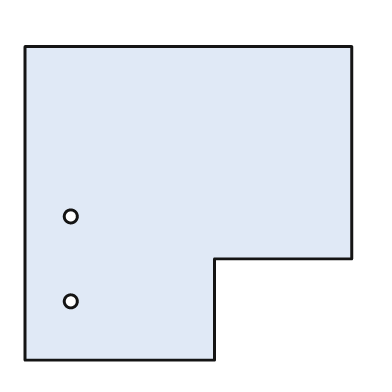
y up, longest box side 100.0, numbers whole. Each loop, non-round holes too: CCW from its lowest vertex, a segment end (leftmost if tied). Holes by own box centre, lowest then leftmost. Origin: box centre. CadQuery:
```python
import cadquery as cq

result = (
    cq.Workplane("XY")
    .moveTo(-50.0, -48.0)
    .lineTo(8.0, -48.0)
    .lineTo(8.0, -17.0)
    .lineTo(50.0, -17.0)
    .lineTo(50.0, 48.0)
    .lineTo(-50.0, 48.0)
    .close()
    .moveTo(-36.0, -30.0)
    .circle(2.0)
    .moveTo(-36.0, -4.0)
    .circle(2.0)
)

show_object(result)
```